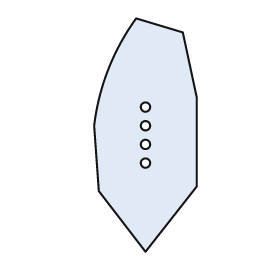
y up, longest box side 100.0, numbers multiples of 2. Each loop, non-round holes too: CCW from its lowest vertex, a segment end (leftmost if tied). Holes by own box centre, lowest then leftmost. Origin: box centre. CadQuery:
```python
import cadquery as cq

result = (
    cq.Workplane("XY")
    .moveTo(0.0, -50.0)
    .lineTo(22.0, -22.0)
    .lineTo(22.0, 16.0)
    .lineTo(16.0, 44.0)
    .lineTo(-4.0, 50.0)
    .threePointArc((-16.0, 28.0), (-22.0, 4.0))
    .lineTo(-20.0, -24.0)
    .close()
    .moveTo(0.0, -12.0)
    .circle(2.0)
    .moveTo(0.0, -4.0)
    .circle(2.0)
    .moveTo(0.0, 4.0)
    .circle(2.0)
    .moveTo(0.0, 12.0)
    .circle(2.0)
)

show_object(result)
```